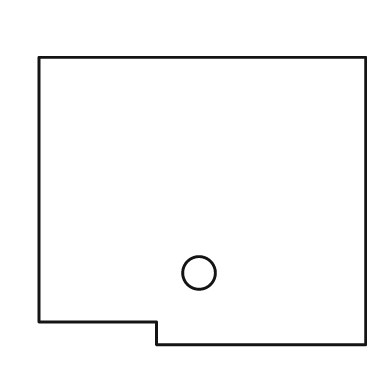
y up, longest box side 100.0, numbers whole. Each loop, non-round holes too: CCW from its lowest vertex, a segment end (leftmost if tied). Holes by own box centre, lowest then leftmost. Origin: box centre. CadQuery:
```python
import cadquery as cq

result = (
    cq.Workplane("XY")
    .moveTo(-14.0, -44.0)
    .lineTo(50.0, -44.0)
    .lineTo(50.0, 44.0)
    .lineTo(-50.0, 44.0)
    .lineTo(-50.0, -37.0)
    .lineTo(-14.0, -37.0)
    .close()
    .moveTo(-1.0, -22.0)
    .circle(5.0)
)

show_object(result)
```